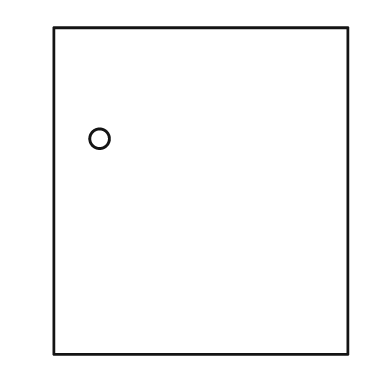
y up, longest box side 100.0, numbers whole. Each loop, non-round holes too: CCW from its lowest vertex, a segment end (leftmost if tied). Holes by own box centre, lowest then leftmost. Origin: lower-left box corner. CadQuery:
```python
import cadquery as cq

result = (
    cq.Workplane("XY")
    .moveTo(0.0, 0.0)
    .lineTo(90.0, 0.0)
    .lineTo(90.0, 100.0)
    .lineTo(0.0, 100.0)
    .close()
    .moveTo(14.0, 66.0)
    .circle(3.0)
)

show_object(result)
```